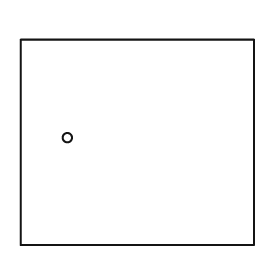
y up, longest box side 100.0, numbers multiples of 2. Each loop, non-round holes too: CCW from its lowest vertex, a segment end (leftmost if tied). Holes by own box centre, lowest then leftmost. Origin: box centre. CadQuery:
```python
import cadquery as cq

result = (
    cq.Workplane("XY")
    .moveTo(-50.0, -44.0)
    .lineTo(50.0, -44.0)
    .lineTo(50.0, 44.0)
    .lineTo(-50.0, 44.0)
    .close()
    .moveTo(-30.0, 2.0)
    .circle(2.0)
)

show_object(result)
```